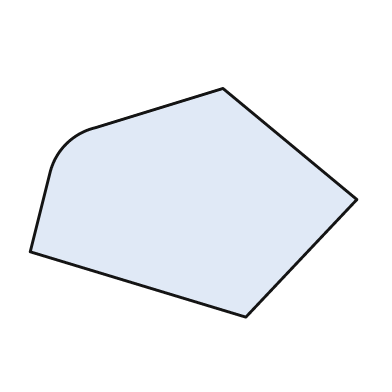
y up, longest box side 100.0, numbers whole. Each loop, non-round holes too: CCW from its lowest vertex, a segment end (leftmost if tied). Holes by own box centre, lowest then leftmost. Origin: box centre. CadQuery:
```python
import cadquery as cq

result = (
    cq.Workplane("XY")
    .moveTo(16.0, -35.0)
    .lineTo(50.0, 1.0)
    .lineTo(9.0, 35.0)
    .lineTo(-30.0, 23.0)
    .threePointArc((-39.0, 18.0), (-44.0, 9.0))
    .lineTo(-50.0, -15.0)
    .close()
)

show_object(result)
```